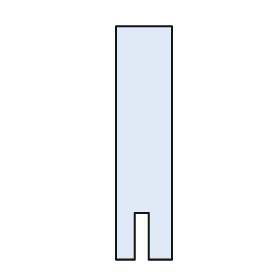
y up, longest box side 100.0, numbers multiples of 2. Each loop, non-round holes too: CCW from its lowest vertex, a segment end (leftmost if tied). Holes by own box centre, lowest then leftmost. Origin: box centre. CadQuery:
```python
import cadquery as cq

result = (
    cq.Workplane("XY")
    .moveTo(-12.0, -50.0)
    .lineTo(-4.0, -50.0)
    .lineTo(-4.0, -30.0)
    .lineTo(2.0, -30.0)
    .lineTo(2.0, -50.0)
    .lineTo(12.0, -50.0)
    .lineTo(12.0, 50.0)
    .lineTo(-12.0, 50.0)
    .close()
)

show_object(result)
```